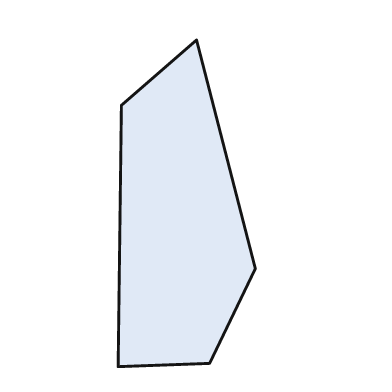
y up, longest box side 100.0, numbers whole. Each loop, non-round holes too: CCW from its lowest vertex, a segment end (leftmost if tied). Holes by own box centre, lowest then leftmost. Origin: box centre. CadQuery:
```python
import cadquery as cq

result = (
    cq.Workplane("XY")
    .moveTo(-21.0, -50.0)
    .lineTo(7.0, -49.0)
    .lineTo(21.0, -20.0)
    .lineTo(3.0, 50.0)
    .lineTo(-20.0, 30.0)
    .close()
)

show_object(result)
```